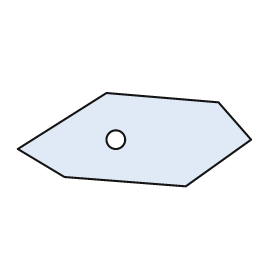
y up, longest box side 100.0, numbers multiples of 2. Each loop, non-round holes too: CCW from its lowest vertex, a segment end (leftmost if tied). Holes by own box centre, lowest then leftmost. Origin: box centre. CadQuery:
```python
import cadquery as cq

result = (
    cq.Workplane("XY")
    .moveTo(22.0, -20.0)
    .lineTo(50.0, 0.0)
    .lineTo(36.0, 16.0)
    .lineTo(-12.0, 20.0)
    .lineTo(-50.0, -4.0)
    .lineTo(-30.0, -16.0)
    .close()
    .moveTo(-8.0, 0.0)
    .circle(4.0)
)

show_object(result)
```